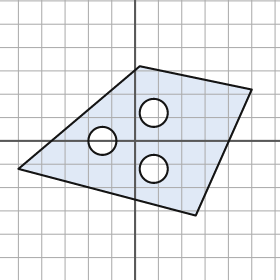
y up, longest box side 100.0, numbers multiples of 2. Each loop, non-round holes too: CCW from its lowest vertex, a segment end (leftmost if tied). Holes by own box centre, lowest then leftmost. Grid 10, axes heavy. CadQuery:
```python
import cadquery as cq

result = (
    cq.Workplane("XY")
    .moveTo(26.0, -32.0)
    .lineTo(50.0, 22.0)
    .lineTo(2.0, 32.0)
    .lineTo(-50.0, -12.0)
    .close()
    .moveTo(8.0, -12.0)
    .circle(6.0)
    .moveTo(-14.0, 0.0)
    .circle(6.0)
    .moveTo(8.0, 12.0)
    .circle(6.0)
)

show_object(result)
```